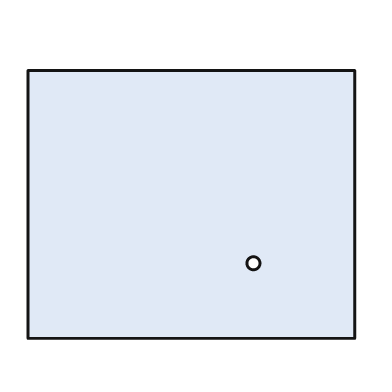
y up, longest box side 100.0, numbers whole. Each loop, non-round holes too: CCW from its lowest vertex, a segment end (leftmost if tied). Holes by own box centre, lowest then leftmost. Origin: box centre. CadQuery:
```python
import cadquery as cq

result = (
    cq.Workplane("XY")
    .moveTo(-50.0, -41.0)
    .lineTo(50.0, -41.0)
    .lineTo(50.0, 41.0)
    .lineTo(-50.0, 41.0)
    .close()
    .moveTo(19.0, -18.0)
    .circle(2.0)
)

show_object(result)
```